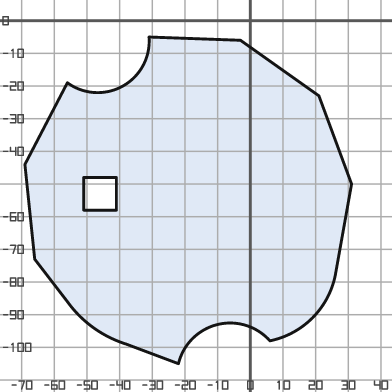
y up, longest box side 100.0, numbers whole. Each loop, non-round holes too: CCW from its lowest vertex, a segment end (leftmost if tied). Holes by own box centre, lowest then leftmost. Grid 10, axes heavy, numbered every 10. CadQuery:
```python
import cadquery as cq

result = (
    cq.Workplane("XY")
    .moveTo(-22.0, -105.0)
    .threePointArc((-10.0, -93.0), (6.0, -98.0))
    .threePointArc((19.0, -91.0), (26.0, -78.0))
    .lineTo(31.0, -50.0)
    .lineTo(21.0, -23.0)
    .lineTo(-3.0, -6.0)
    .lineTo(-31.0, -5.0)
    .threePointArc((-39.0, -20.0), (-56.0, -19.0))
    .lineTo(-69.0, -44.0)
    .lineTo(-66.0, -73.0)
    .lineTo(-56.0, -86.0)
    .threePointArc((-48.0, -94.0), (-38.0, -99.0))
    .close()
    .moveTo(-51.0, -58.0)
    .lineTo(-41.0, -58.0)
    .lineTo(-41.0, -48.0)
    .lineTo(-51.0, -48.0)
    .close()
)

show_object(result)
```